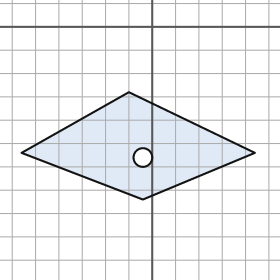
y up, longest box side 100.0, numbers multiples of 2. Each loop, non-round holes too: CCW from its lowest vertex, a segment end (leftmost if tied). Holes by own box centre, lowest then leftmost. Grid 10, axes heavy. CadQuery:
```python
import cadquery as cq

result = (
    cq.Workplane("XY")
    .moveTo(-4.0, -74.0)
    .lineTo(44.0, -54.0)
    .lineTo(-10.0, -28.0)
    .lineTo(-56.0, -54.0)
    .close()
    .moveTo(-4.0, -56.0)
    .circle(4.0)
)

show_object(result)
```